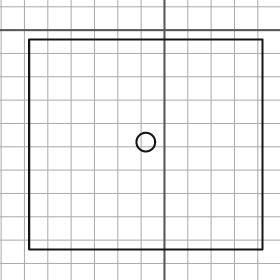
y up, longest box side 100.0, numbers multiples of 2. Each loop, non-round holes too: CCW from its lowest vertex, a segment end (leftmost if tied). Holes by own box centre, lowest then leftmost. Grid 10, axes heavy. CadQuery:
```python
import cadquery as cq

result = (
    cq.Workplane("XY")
    .moveTo(-58.0, -94.0)
    .lineTo(42.0, -94.0)
    .lineTo(42.0, -4.0)
    .lineTo(-58.0, -4.0)
    .close()
    .moveTo(-8.0, -48.0)
    .circle(4.0)
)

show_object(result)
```